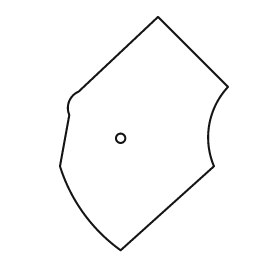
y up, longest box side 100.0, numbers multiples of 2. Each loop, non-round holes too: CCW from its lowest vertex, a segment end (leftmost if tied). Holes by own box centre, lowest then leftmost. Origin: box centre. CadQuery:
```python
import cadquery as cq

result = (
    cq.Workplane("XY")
    .moveTo(-10.0, -50.0)
    .lineTo(30.0, -14.0)
    .threePointArc((28.0, 4.0), (36.0, 20.0))
    .lineTo(6.0, 50.0)
    .lineTo(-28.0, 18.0)
    .threePointArc((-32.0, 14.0), (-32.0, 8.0))
    .lineTo(-36.0, -14.0)
    .threePointArc((-26.0, -34.0), (-10.0, -50.0))
    .close()
    .moveTo(-10.0, -2.0)
    .circle(2.0)
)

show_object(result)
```